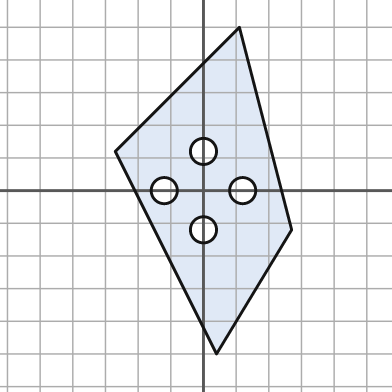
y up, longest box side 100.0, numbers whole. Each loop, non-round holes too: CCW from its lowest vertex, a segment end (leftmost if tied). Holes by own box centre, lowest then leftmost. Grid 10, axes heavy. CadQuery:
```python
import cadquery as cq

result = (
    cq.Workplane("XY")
    .moveTo(4.0, -50.0)
    .lineTo(27.0, -12.0)
    .lineTo(11.0, 50.0)
    .lineTo(-27.0, 12.0)
    .close()
    .moveTo(0.0, -12.0)
    .circle(4.0)
    .moveTo(-12.0, 0.0)
    .circle(4.0)
    .moveTo(12.0, 0.0)
    .circle(4.0)
    .moveTo(0.0, 12.0)
    .circle(4.0)
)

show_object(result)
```